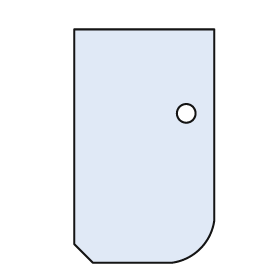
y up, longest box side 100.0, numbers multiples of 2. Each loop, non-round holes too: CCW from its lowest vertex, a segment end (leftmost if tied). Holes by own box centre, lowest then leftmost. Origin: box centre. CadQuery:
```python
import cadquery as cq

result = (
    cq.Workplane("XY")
    .moveTo(-22.0, -50.0)
    .lineTo(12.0, -50.0)
    .threePointArc((24.0, -44.0), (30.0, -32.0))
    .lineTo(30.0, 50.0)
    .lineTo(-30.0, 50.0)
    .lineTo(-30.0, -42.0)
    .close()
    .moveTo(18.0, 14.0)
    .circle(4.0)
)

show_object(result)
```